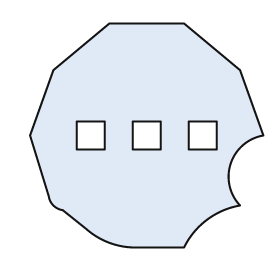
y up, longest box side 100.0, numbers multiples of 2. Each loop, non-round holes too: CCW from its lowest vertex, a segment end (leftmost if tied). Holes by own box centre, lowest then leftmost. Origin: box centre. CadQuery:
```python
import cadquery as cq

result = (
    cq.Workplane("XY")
    .moveTo(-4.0, -48.0)
    .lineTo(16.0, -48.0)
    .threePointArc((26.0, -36.0), (40.0, -30.0))
    .threePointArc((36.0, -12.0), (50.0, 0.0))
    .lineTo(40.0, 28.0)
    .lineTo(16.0, 48.0)
    .lineTo(-16.0, 48.0)
    .lineTo(-40.0, 28.0)
    .lineTo(-50.0, 0.0)
    .lineTo(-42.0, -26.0)
    .threePointArc((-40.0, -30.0), (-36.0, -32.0))
    .lineTo(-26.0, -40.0)
    .threePointArc((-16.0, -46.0), (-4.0, -48.0))
    .close()
    .moveTo(-30.0, -6.0)
    .lineTo(-18.0, -6.0)
    .lineTo(-18.0, 6.0)
    .lineTo(-30.0, 6.0)
    .close()
    .moveTo(-6.0, -6.0)
    .lineTo(6.0, -6.0)
    .lineTo(6.0, 6.0)
    .lineTo(-6.0, 6.0)
    .close()
    .moveTo(18.0, -6.0)
    .lineTo(30.0, -6.0)
    .lineTo(30.0, 6.0)
    .lineTo(18.0, 6.0)
    .close()
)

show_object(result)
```